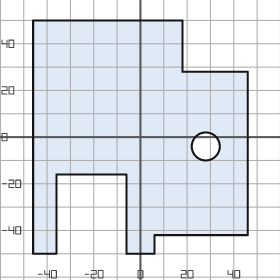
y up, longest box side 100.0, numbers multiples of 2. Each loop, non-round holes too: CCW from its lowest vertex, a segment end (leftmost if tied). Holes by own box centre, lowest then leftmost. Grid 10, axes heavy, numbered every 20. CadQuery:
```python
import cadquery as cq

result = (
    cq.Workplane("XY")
    .moveTo(-46.0, -50.0)
    .lineTo(-36.0, -50.0)
    .lineTo(-36.0, -16.0)
    .lineTo(-6.0, -16.0)
    .lineTo(-6.0, -50.0)
    .lineTo(6.0, -50.0)
    .lineTo(6.0, -42.0)
    .lineTo(46.0, -42.0)
    .lineTo(46.0, 28.0)
    .lineTo(18.0, 28.0)
    .lineTo(18.0, 50.0)
    .lineTo(-46.0, 50.0)
    .close()
    .moveTo(28.0, -4.0)
    .circle(6.0)
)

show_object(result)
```